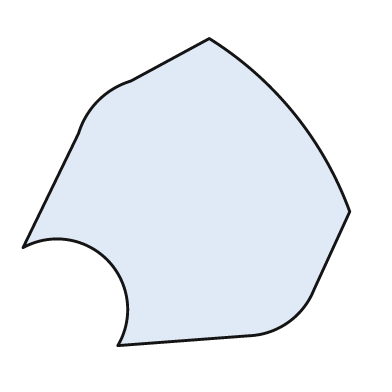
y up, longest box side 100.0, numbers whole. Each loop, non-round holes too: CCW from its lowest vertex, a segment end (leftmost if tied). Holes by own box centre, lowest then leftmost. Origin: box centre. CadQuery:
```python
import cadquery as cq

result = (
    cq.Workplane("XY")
    .moveTo(-21.0, -47.0)
    .lineTo(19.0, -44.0)
    .threePointArc((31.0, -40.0), (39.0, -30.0))
    .lineTo(50.0, -6.0)
    .threePointArc((33.0, 24.0), (7.0, 47.0))
    .lineTo(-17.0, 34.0)
    .threePointArc((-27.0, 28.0), (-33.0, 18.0))
    .lineTo(-50.0, -17.0)
    .threePointArc((-24.0, -21.0), (-21.0, -47.0))
    .close()
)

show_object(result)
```